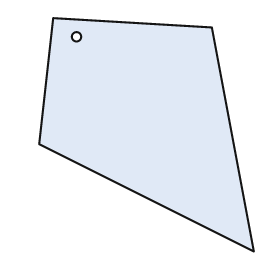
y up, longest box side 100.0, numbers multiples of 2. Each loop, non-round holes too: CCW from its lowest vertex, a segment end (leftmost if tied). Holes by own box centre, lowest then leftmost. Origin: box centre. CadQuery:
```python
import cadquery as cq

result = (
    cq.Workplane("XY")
    .moveTo(46.0, -50.0)
    .lineTo(28.0, 46.0)
    .lineTo(-40.0, 50.0)
    .lineTo(-46.0, -4.0)
    .close()
    .moveTo(-30.0, 42.0)
    .circle(2.0)
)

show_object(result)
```